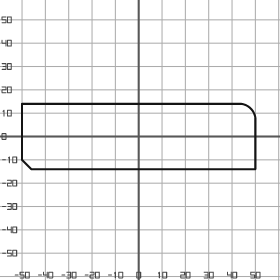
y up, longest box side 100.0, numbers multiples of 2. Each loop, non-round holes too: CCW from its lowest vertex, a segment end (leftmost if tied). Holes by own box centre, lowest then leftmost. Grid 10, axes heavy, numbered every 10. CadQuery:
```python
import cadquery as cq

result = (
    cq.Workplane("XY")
    .moveTo(-46.0, -14.0)
    .lineTo(50.0, -14.0)
    .lineTo(50.0, 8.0)
    .threePointArc((48.0, 12.0), (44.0, 14.0))
    .lineTo(-50.0, 14.0)
    .lineTo(-50.0, -10.0)
    .close()
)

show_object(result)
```